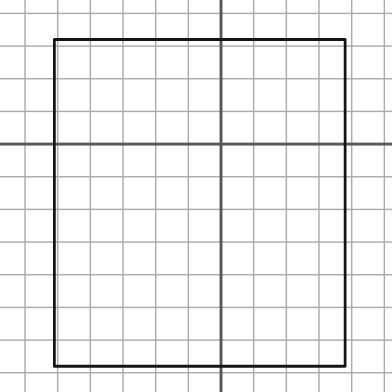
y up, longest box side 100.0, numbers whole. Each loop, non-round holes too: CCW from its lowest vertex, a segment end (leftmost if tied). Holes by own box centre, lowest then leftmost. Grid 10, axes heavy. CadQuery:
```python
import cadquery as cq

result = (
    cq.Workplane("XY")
    .moveTo(-51.0, -68.0)
    .lineTo(38.0, -68.0)
    .lineTo(38.0, 32.0)
    .lineTo(-51.0, 32.0)
    .close()
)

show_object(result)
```